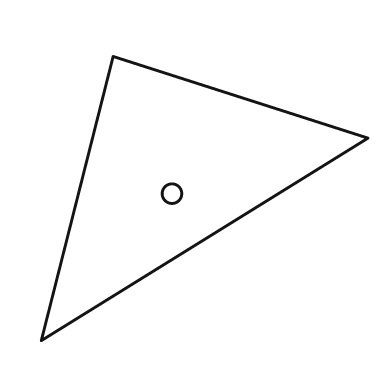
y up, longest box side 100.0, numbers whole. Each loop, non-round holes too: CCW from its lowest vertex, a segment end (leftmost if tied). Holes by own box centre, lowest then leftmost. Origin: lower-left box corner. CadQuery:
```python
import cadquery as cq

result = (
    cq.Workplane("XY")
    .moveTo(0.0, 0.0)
    .lineTo(100.0, 62.0)
    .lineTo(22.0, 87.0)
    .close()
    .moveTo(40.0, 45.0)
    .circle(3.0)
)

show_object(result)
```